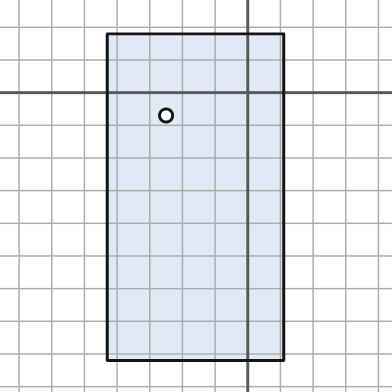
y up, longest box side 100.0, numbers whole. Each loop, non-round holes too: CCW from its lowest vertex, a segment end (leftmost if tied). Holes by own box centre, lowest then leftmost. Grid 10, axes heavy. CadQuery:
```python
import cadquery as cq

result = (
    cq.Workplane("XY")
    .moveTo(-43.0, -82.0)
    .lineTo(11.0, -82.0)
    .lineTo(11.0, 18.0)
    .lineTo(-43.0, 18.0)
    .close()
    .moveTo(-25.0, -7.0)
    .circle(2.0)
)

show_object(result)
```